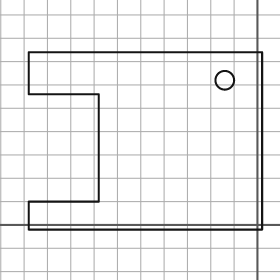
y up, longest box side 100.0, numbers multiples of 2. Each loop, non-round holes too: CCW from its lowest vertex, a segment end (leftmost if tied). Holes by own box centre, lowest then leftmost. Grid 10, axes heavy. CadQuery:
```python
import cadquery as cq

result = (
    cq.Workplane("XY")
    .moveTo(-98.0, -2.0)
    .lineTo(2.0, -2.0)
    .lineTo(2.0, 74.0)
    .lineTo(-98.0, 74.0)
    .lineTo(-98.0, 56.0)
    .lineTo(-68.0, 56.0)
    .lineTo(-68.0, 10.0)
    .lineTo(-98.0, 10.0)
    .close()
    .moveTo(-14.0, 62.0)
    .circle(4.0)
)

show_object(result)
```